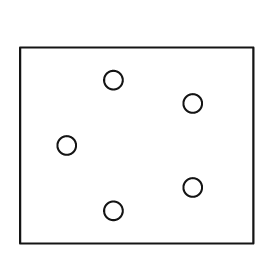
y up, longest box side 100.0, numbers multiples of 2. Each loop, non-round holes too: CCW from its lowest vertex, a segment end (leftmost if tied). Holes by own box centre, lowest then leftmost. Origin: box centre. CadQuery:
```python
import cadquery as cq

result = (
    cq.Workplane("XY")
    .moveTo(-50.0, -42.0)
    .lineTo(50.0, -42.0)
    .lineTo(50.0, 42.0)
    .lineTo(-50.0, 42.0)
    .close()
    .moveTo(-10.0, -28.0)
    .circle(4.0)
    .moveTo(24.0, -18.0)
    .circle(4.0)
    .moveTo(-30.0, 0.0)
    .circle(4.0)
    .moveTo(24.0, 18.0)
    .circle(4.0)
    .moveTo(-10.0, 28.0)
    .circle(4.0)
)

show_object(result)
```